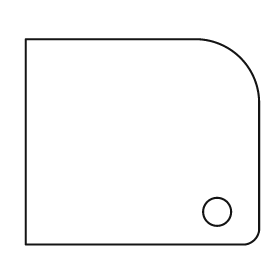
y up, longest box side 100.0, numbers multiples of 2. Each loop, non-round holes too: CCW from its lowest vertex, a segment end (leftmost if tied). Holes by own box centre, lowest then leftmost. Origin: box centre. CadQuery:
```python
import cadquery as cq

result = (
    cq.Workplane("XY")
    .moveTo(-50.0, -44.0)
    .lineTo(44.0, -44.0)
    .threePointArc((48.0, -42.0), (50.0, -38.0))
    .lineTo(50.0, 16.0)
    .threePointArc((42.0, 36.0), (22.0, 44.0))
    .lineTo(-50.0, 44.0)
    .close()
    .moveTo(32.0, -30.0)
    .circle(6.0)
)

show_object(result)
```